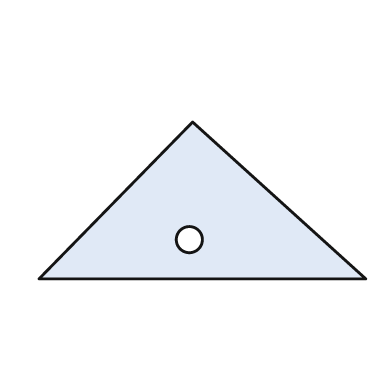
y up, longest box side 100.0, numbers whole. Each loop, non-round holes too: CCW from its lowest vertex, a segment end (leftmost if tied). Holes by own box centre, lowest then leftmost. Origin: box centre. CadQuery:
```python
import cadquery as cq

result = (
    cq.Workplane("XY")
    .moveTo(-50.0, -24.0)
    .lineTo(50.0, -24.0)
    .lineTo(-3.0, 24.0)
    .close()
    .moveTo(-4.0, -12.0)
    .circle(4.0)
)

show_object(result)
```